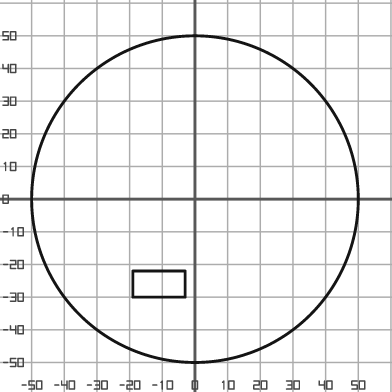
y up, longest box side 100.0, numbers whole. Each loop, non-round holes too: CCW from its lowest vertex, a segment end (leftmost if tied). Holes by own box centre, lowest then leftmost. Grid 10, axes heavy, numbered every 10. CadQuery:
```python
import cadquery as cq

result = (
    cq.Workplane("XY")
    .moveTo(0.0, 0.0)
    .circle(50.0)
    .moveTo(-19.0, -30.0)
    .lineTo(-3.0, -30.0)
    .lineTo(-3.0, -22.0)
    .lineTo(-19.0, -22.0)
    .close()
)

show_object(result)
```